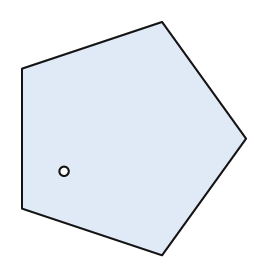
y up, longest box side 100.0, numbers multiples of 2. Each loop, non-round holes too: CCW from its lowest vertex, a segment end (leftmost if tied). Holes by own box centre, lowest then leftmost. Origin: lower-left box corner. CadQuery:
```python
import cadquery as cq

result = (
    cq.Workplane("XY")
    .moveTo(60.0, 0.0)
    .lineTo(96.0, 50.0)
    .lineTo(60.0, 100.0)
    .lineTo(0.0, 80.0)
    .lineTo(0.0, 20.0)
    .close()
    .moveTo(18.0, 36.0)
    .circle(2.0)
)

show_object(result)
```